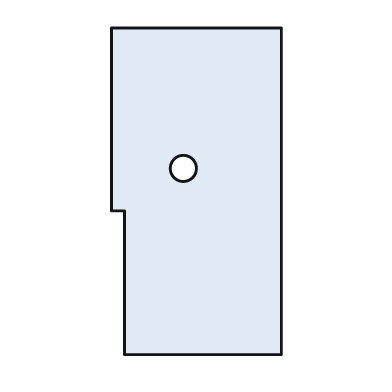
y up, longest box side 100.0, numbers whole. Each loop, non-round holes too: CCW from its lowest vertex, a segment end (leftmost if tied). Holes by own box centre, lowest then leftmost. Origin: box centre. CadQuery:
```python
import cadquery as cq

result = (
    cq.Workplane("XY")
    .moveTo(-22.0, -50.0)
    .lineTo(26.0, -50.0)
    .lineTo(26.0, 50.0)
    .lineTo(-26.0, 50.0)
    .lineTo(-26.0, -6.0)
    .lineTo(-22.0, -6.0)
    .close()
    .moveTo(-4.0, 7.0)
    .circle(4.0)
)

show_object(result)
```